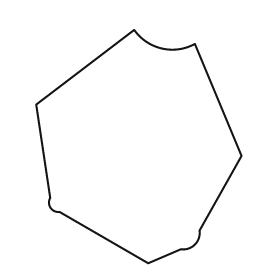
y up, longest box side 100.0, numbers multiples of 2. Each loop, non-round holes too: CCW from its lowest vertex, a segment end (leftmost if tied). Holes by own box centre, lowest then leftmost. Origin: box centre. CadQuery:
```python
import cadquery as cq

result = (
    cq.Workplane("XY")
    .moveTo(4.0, -50.0)
    .lineTo(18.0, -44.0)
    .threePointArc((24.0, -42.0), (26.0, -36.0))
    .lineTo(44.0, -4.0)
    .lineTo(24.0, 44.0)
    .threePointArc((10.0, 42.0), (-2.0, 50.0))
    .lineTo(-44.0, 18.0)
    .lineTo(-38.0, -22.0)
    .threePointArc((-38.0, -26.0), (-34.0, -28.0))
    .close()
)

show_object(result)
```